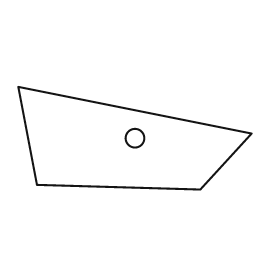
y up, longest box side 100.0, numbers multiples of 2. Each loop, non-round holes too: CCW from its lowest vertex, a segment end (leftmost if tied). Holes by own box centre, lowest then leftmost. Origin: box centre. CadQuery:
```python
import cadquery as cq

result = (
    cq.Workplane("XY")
    .moveTo(28.0, -22.0)
    .lineTo(50.0, 2.0)
    .lineTo(-50.0, 22.0)
    .lineTo(-42.0, -20.0)
    .close()
    .moveTo(0.0, 0.0)
    .circle(4.0)
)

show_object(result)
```